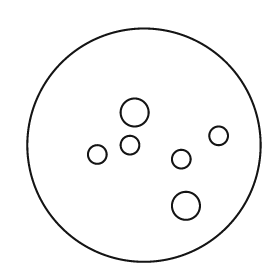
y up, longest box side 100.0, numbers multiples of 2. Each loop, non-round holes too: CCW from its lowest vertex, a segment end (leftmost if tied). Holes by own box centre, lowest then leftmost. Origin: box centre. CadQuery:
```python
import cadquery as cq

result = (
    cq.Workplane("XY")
    .moveTo(0.0, 0.0)
    .circle(50.0)
    .moveTo(18.0, -26.0)
    .circle(6.0)
    .moveTo(16.0, -6.0)
    .circle(4.0)
    .moveTo(-20.0, -4.0)
    .circle(4.0)
    .moveTo(-6.0, 0.0)
    .circle(4.0)
    .moveTo(32.0, 4.0)
    .circle(4.0)
    .moveTo(-4.0, 14.0)
    .circle(6.0)
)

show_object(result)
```